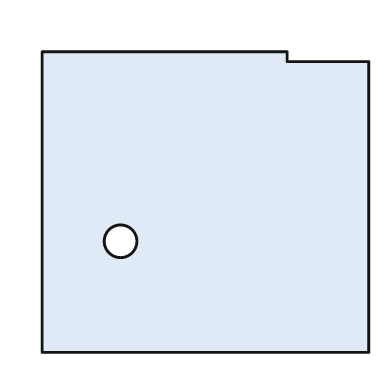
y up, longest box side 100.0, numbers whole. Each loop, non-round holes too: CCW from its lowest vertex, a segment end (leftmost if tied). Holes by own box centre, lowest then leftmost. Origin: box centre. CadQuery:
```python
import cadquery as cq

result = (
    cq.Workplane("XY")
    .moveTo(-50.0, -46.0)
    .lineTo(50.0, -46.0)
    .lineTo(50.0, 43.0)
    .lineTo(25.0, 43.0)
    .lineTo(25.0, 46.0)
    .lineTo(-50.0, 46.0)
    .close()
    .moveTo(-26.0, -12.0)
    .circle(5.0)
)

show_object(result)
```